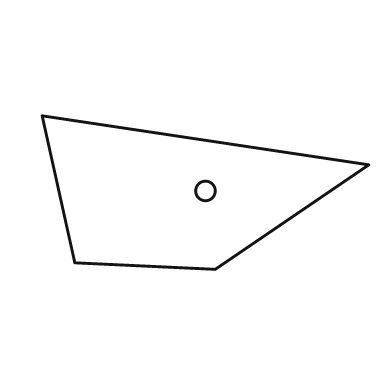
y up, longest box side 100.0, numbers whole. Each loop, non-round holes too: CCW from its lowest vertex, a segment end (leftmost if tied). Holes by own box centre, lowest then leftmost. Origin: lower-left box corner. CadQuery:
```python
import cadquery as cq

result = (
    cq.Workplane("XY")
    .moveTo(53.0, 0.0)
    .lineTo(100.0, 32.0)
    .lineTo(0.0, 47.0)
    .lineTo(10.0, 2.0)
    .close()
    .moveTo(50.0, 24.0)
    .circle(3.0)
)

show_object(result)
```